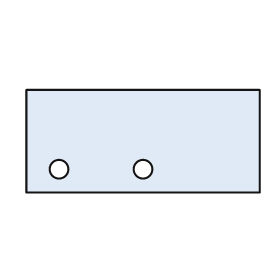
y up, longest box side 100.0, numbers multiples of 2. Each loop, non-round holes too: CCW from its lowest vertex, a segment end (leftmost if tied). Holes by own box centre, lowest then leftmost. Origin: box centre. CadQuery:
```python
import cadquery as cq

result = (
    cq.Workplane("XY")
    .moveTo(-50.0, -22.0)
    .lineTo(50.0, -22.0)
    .lineTo(50.0, 22.0)
    .lineTo(-50.0, 22.0)
    .close()
    .moveTo(-36.0, -12.0)
    .circle(4.0)
    .moveTo(0.0, -12.0)
    .circle(4.0)
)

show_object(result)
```